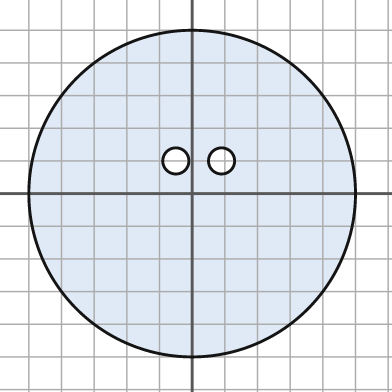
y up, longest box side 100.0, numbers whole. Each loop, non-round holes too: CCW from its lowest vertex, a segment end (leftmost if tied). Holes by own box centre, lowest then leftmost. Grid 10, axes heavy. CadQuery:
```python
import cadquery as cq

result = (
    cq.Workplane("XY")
    .moveTo(0.0, 0.0)
    .circle(50.0)
    .moveTo(-5.0, 10.0)
    .circle(4.0)
    .moveTo(9.0, 10.0)
    .circle(4.0)
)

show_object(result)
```